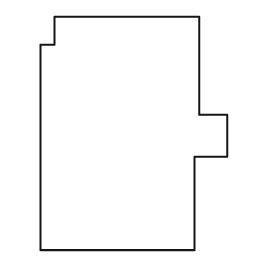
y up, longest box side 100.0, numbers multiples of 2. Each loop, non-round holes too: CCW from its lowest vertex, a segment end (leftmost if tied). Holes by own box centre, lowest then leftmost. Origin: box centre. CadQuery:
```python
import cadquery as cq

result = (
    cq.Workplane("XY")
    .moveTo(-40.0, -50.0)
    .lineTo(26.0, -50.0)
    .lineTo(26.0, -10.0)
    .lineTo(40.0, -10.0)
    .lineTo(40.0, 8.0)
    .lineTo(28.0, 8.0)
    .lineTo(28.0, 50.0)
    .lineTo(-34.0, 50.0)
    .lineTo(-34.0, 38.0)
    .lineTo(-40.0, 38.0)
    .close()
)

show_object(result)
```